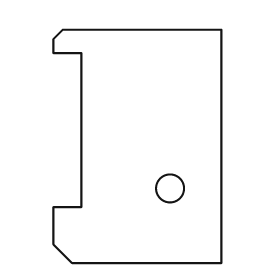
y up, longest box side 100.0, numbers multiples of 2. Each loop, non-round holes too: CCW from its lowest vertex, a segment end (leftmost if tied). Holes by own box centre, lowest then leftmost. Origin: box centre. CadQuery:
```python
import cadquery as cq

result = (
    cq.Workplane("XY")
    .moveTo(-28.0, -50.0)
    .lineTo(36.0, -50.0)
    .lineTo(36.0, 50.0)
    .lineTo(-32.0, 50.0)
    .lineTo(-36.0, 46.0)
    .lineTo(-36.0, 40.0)
    .lineTo(-24.0, 40.0)
    .lineTo(-24.0, -26.0)
    .lineTo(-36.0, -26.0)
    .lineTo(-36.0, -42.0)
    .close()
    .moveTo(14.0, -18.0)
    .circle(6.0)
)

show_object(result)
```